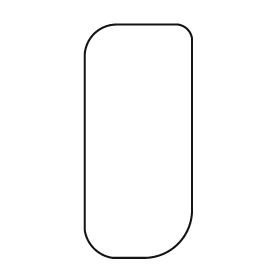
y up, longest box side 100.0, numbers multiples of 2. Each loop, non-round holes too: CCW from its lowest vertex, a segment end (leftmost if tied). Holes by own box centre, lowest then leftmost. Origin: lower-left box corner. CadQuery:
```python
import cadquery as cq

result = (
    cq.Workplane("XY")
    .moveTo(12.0, 0.0)
    .lineTo(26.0, 0.0)
    .threePointArc((40.0, 6.0), (46.0, 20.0))
    .lineTo(46.0, 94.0)
    .threePointArc((44.0, 98.0), (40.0, 100.0))
    .lineTo(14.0, 100.0)
    .threePointArc((4.0, 96.0), (0.0, 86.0))
    .lineTo(0.0, 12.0)
    .threePointArc((4.0, 4.0), (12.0, 0.0))
    .close()
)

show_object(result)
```